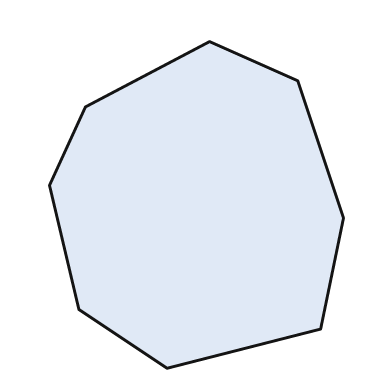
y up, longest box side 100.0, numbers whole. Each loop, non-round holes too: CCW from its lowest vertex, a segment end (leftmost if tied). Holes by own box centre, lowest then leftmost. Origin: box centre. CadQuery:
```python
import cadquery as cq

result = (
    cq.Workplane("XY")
    .moveTo(-9.0, -50.0)
    .lineTo(38.0, -38.0)
    .lineTo(45.0, -4.0)
    .lineTo(31.0, 38.0)
    .lineTo(4.0, 50.0)
    .lineTo(-34.0, 30.0)
    .lineTo(-45.0, 6.0)
    .lineTo(-36.0, -32.0)
    .close()
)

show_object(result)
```